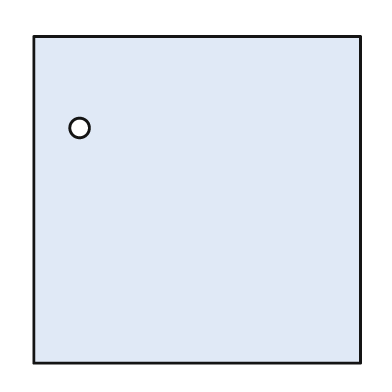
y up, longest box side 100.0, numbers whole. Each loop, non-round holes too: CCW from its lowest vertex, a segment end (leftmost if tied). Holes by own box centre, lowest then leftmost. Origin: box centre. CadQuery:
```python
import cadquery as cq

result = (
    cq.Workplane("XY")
    .moveTo(-50.0, -50.0)
    .lineTo(50.0, -50.0)
    .lineTo(50.0, 50.0)
    .lineTo(-50.0, 50.0)
    .close()
    .moveTo(-36.0, 22.0)
    .circle(3.0)
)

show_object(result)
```